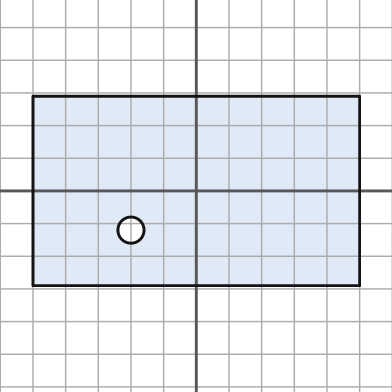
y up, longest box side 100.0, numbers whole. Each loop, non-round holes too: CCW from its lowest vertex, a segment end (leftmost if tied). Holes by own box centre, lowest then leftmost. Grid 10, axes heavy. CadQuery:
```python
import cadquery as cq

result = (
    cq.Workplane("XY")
    .moveTo(-50.0, -29.0)
    .lineTo(50.0, -29.0)
    .lineTo(50.0, 29.0)
    .lineTo(-50.0, 29.0)
    .close()
    .moveTo(-20.0, -12.0)
    .circle(4.0)
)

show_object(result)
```